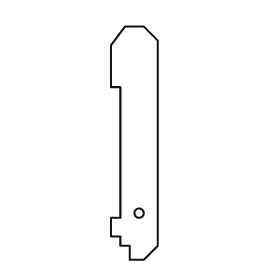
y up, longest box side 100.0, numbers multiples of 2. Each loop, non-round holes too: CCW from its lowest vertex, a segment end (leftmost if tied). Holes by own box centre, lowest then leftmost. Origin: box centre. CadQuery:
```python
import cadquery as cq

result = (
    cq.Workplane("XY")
    .moveTo(-2.0, -50.0)
    .lineTo(4.0, -50.0)
    .lineTo(10.0, -44.0)
    .lineTo(10.0, 44.0)
    .lineTo(4.0, 50.0)
    .lineTo(-4.0, 50.0)
    .lineTo(-10.0, 42.0)
    .lineTo(-10.0, 24.0)
    .lineTo(-6.0, 24.0)
    .lineTo(-6.0, -32.0)
    .lineTo(-10.0, -32.0)
    .lineTo(-10.0, -40.0)
    .lineTo(-6.0, -40.0)
    .lineTo(-6.0, -44.0)
    .lineTo(-2.0, -44.0)
    .close()
    .moveTo(2.0, -30.0)
    .circle(2.0)
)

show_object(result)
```